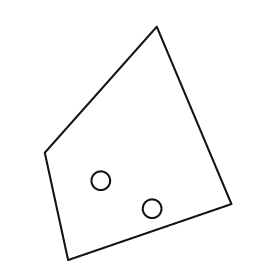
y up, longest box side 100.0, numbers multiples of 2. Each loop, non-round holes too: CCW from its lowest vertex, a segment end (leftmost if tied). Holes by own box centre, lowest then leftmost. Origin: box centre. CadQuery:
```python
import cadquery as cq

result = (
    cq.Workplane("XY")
    .moveTo(-30.0, -50.0)
    .lineTo(40.0, -26.0)
    .lineTo(8.0, 50.0)
    .lineTo(-40.0, -4.0)
    .close()
    .moveTo(6.0, -28.0)
    .circle(4.0)
    .moveTo(-16.0, -16.0)
    .circle(4.0)
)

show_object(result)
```